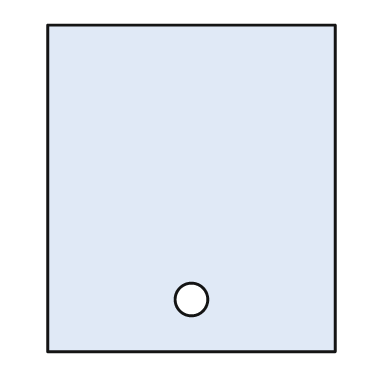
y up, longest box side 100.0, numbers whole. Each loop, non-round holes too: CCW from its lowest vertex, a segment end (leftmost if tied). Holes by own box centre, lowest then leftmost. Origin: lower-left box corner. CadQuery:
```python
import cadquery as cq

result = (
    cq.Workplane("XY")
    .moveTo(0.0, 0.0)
    .lineTo(88.0, 0.0)
    .lineTo(88.0, 100.0)
    .lineTo(0.0, 100.0)
    .close()
    .moveTo(44.0, 16.0)
    .circle(5.0)
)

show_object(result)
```